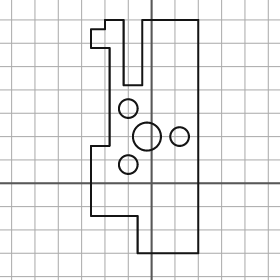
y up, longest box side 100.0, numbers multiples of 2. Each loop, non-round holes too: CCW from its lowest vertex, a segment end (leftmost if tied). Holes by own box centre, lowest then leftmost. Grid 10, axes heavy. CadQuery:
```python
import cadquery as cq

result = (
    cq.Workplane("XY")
    .moveTo(-6.0, -30.0)
    .lineTo(20.0, -30.0)
    .lineTo(20.0, 70.0)
    .lineTo(-4.0, 70.0)
    .lineTo(-4.0, 42.0)
    .lineTo(-12.0, 42.0)
    .lineTo(-12.0, 70.0)
    .lineTo(-20.0, 70.0)
    .lineTo(-20.0, 66.0)
    .lineTo(-26.0, 66.0)
    .lineTo(-26.0, 58.0)
    .lineTo(-18.0, 58.0)
    .lineTo(-18.0, 16.0)
    .lineTo(-26.0, 16.0)
    .lineTo(-26.0, -14.0)
    .lineTo(-6.0, -14.0)
    .close()
    .moveTo(-10.0, 8.0)
    .circle(4.0)
    .moveTo(-2.0, 20.0)
    .circle(6.0)
    .moveTo(12.0, 20.0)
    .circle(4.0)
    .moveTo(-10.0, 32.0)
    .circle(4.0)
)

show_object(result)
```